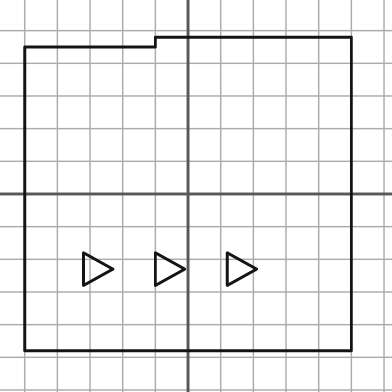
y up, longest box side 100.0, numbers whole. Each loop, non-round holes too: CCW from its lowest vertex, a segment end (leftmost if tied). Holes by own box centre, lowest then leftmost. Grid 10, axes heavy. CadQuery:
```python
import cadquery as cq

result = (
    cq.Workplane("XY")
    .moveTo(-50.0, -48.0)
    .lineTo(50.0, -48.0)
    .lineTo(50.0, 48.0)
    .lineTo(-10.0, 48.0)
    .lineTo(-10.0, 45.0)
    .lineTo(-50.0, 45.0)
    .close()
    .moveTo(-32.0, -28.0)
    .lineTo(-23.0, -23.0)
    .lineTo(-32.0, -18.0)
    .close()
    .moveTo(-10.0, -28.0)
    .lineTo(-1.0, -23.0)
    .lineTo(-10.0, -18.0)
    .close()
    .moveTo(12.0, -28.0)
    .lineTo(21.0, -23.0)
    .lineTo(12.0, -18.0)
    .close()
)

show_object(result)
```